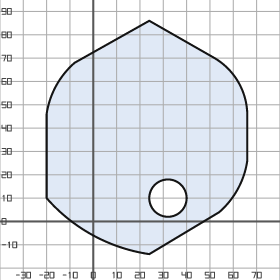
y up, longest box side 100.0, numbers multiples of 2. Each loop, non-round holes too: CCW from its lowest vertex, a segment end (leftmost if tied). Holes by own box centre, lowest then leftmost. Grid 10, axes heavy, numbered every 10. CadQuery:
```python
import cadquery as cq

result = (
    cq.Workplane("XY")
    .moveTo(24.0, -14.0)
    .lineTo(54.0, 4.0)
    .threePointArc((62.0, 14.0), (66.0, 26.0))
    .lineTo(66.0, 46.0)
    .threePointArc((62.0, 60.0), (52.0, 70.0))
    .lineTo(24.0, 86.0)
    .lineTo(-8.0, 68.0)
    .threePointArc((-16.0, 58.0), (-20.0, 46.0))
    .lineTo(-20.0, 10.0)
    .threePointArc((0.0, -6.0), (24.0, -14.0))
    .close()
    .moveTo(32.0, 10.0)
    .circle(8.0)
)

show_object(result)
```